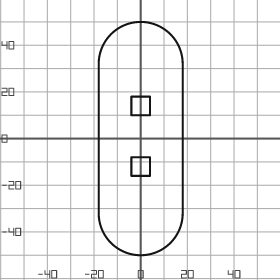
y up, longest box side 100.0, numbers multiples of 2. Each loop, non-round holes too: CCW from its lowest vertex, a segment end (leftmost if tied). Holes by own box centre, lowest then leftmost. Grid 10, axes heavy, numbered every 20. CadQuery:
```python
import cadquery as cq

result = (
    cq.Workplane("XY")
    .moveTo(-18.0, -32.0)
    .threePointArc((0.0, -50.0), (18.0, -32.0))
    .lineTo(18.0, 32.0)
    .threePointArc((0.0, 50.0), (-18.0, 32.0))
    .close()
    .moveTo(-4.0, -16.0)
    .lineTo(4.0, -16.0)
    .lineTo(4.0, -8.0)
    .lineTo(-4.0, -8.0)
    .close()
    .moveTo(-4.0, 10.0)
    .lineTo(4.0, 10.0)
    .lineTo(4.0, 18.0)
    .lineTo(-4.0, 18.0)
    .close()
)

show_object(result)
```